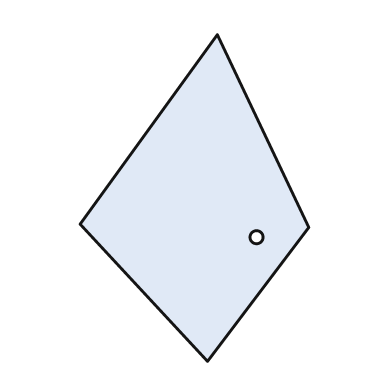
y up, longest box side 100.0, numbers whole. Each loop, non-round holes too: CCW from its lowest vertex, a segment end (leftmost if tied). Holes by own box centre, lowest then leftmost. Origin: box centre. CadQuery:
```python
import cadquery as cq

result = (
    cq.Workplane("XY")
    .moveTo(4.0, -50.0)
    .lineTo(35.0, -9.0)
    .lineTo(7.0, 50.0)
    .lineTo(-35.0, -8.0)
    .close()
    .moveTo(19.0, -12.0)
    .circle(2.0)
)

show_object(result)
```